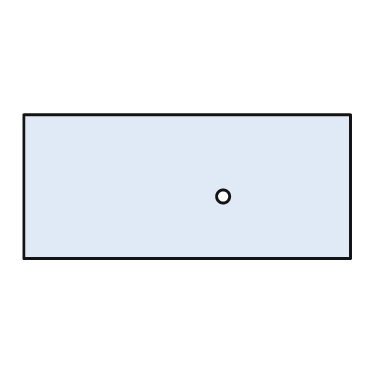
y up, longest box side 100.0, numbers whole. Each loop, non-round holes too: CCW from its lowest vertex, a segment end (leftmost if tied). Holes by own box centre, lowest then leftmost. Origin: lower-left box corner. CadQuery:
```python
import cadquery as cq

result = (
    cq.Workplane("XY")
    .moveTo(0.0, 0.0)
    .lineTo(100.0, 0.0)
    .lineTo(100.0, 44.0)
    .lineTo(0.0, 44.0)
    .close()
    .moveTo(61.0, 19.0)
    .circle(2.0)
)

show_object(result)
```